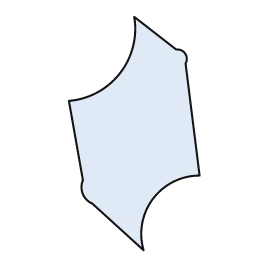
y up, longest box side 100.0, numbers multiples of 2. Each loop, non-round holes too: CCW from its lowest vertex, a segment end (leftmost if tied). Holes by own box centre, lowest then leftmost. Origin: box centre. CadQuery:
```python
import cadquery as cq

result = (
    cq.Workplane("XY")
    .moveTo(4.0, -50.0)
    .threePointArc((8.0, -28.0), (28.0, -18.0))
    .lineTo(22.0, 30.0)
    .threePointArc((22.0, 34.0), (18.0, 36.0))
    .lineTo(0.0, 50.0)
    .threePointArc((-6.0, 26.0), (-28.0, 14.0))
    .lineTo(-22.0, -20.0)
    .threePointArc((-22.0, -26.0), (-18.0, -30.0))
    .close()
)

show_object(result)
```